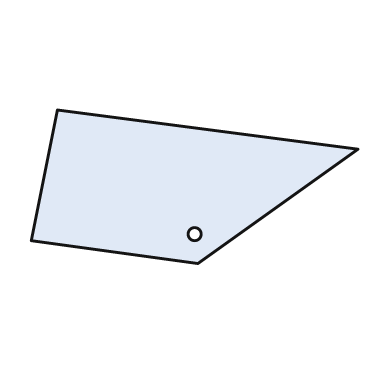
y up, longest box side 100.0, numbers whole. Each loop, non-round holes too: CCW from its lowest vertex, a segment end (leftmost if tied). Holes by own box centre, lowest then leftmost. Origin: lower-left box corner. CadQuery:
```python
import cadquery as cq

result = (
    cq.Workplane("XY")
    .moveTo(51.0, 0.0)
    .lineTo(100.0, 35.0)
    .lineTo(8.0, 47.0)
    .lineTo(0.0, 7.0)
    .close()
    .moveTo(50.0, 9.0)
    .circle(2.0)
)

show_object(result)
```